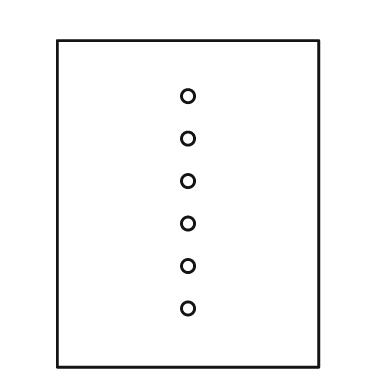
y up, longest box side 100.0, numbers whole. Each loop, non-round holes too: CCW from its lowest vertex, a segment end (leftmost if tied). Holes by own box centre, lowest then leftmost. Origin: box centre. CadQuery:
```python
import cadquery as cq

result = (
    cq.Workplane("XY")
    .moveTo(-40.0, -50.0)
    .lineTo(40.0, -50.0)
    .lineTo(40.0, 50.0)
    .lineTo(-40.0, 50.0)
    .close()
    .moveTo(0.0, -32.0)
    .circle(2.0)
    .moveTo(0.0, -19.0)
    .circle(2.0)
    .moveTo(0.0, -6.0)
    .circle(2.0)
    .moveTo(0.0, 7.0)
    .circle(2.0)
    .moveTo(0.0, 20.0)
    .circle(2.0)
    .moveTo(0.0, 33.0)
    .circle(2.0)
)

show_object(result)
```